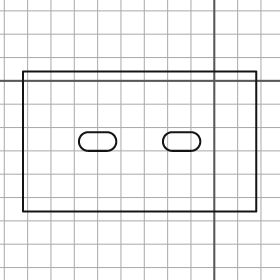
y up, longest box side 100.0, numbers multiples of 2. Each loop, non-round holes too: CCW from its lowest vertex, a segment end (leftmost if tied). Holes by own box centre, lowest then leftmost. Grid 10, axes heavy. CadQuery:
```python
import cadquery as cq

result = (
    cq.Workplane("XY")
    .moveTo(-82.0, -56.0)
    .lineTo(18.0, -56.0)
    .lineTo(18.0, 4.0)
    .lineTo(-82.0, 4.0)
    .close()
    .moveTo(-54.0, -30.0)
    .lineTo(-46.0, -30.0)
    .threePointArc((-42.0, -26.0), (-46.0, -22.0))
    .lineTo(-54.0, -22.0)
    .threePointArc((-58.0, -26.0), (-54.0, -30.0))
    .close()
    .moveTo(-18.0, -30.0)
    .lineTo(-10.0, -30.0)
    .threePointArc((-6.0, -26.0), (-10.0, -22.0))
    .lineTo(-18.0, -22.0)
    .threePointArc((-22.0, -26.0), (-18.0, -30.0))
    .close()
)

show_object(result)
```